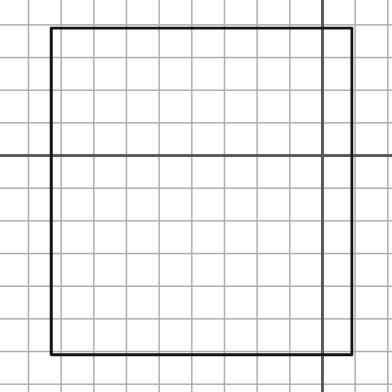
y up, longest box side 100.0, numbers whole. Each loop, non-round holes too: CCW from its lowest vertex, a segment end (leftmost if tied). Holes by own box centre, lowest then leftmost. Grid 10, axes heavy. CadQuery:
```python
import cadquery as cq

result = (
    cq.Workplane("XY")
    .moveTo(-83.0, -61.0)
    .lineTo(9.0, -61.0)
    .lineTo(9.0, 39.0)
    .lineTo(-83.0, 39.0)
    .close()
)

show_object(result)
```